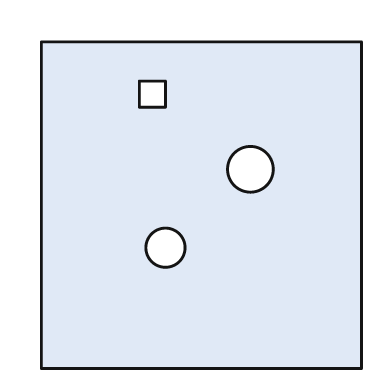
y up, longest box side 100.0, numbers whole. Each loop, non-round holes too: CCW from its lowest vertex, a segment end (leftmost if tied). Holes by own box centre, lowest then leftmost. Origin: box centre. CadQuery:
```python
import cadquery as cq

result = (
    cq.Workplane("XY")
    .moveTo(-49.0, -50.0)
    .lineTo(49.0, -50.0)
    .lineTo(49.0, 50.0)
    .lineTo(-49.0, 50.0)
    .close()
    .moveTo(-11.0, -13.0)
    .circle(6.0)
    .moveTo(15.0, 11.0)
    .circle(7.0)
    .moveTo(-19.0, 30.0)
    .lineTo(-11.0, 30.0)
    .lineTo(-11.0, 38.0)
    .lineTo(-19.0, 38.0)
    .close()
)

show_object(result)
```